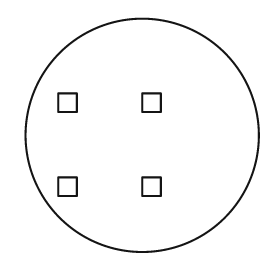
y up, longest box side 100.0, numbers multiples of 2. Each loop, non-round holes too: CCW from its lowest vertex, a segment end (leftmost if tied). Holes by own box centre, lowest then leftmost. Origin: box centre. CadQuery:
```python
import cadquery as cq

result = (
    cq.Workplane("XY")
    .moveTo(0.0, 0.0)
    .circle(50.0)
    .moveTo(-36.0, -26.0)
    .lineTo(-28.0, -26.0)
    .lineTo(-28.0, -18.0)
    .lineTo(-36.0, -18.0)
    .close()
    .moveTo(0.0, -26.0)
    .lineTo(8.0, -26.0)
    .lineTo(8.0, -18.0)
    .lineTo(0.0, -18.0)
    .close()
    .moveTo(-36.0, 10.0)
    .lineTo(-28.0, 10.0)
    .lineTo(-28.0, 18.0)
    .lineTo(-36.0, 18.0)
    .close()
    .moveTo(0.0, 10.0)
    .lineTo(8.0, 10.0)
    .lineTo(8.0, 18.0)
    .lineTo(0.0, 18.0)
    .close()
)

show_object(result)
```